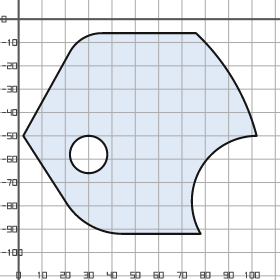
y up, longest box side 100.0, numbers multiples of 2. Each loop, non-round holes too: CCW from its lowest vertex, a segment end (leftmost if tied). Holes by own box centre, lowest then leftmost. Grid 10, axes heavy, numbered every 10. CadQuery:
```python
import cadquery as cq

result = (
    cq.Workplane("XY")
    .moveTo(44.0, -92.0)
    .lineTo(78.0, -92.0)
    .threePointArc((78.0, -64.0), (102.0, -50.0))
    .threePointArc((92.0, -26.0), (76.0, -6.0))
    .lineTo(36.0, -6.0)
    .threePointArc((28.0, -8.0), (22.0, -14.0))
    .lineTo(2.0, -50.0)
    .lineTo(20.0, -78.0)
    .threePointArc((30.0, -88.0), (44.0, -92.0))
    .close()
    .moveTo(30.0, -58.0)
    .circle(8.0)
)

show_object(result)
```